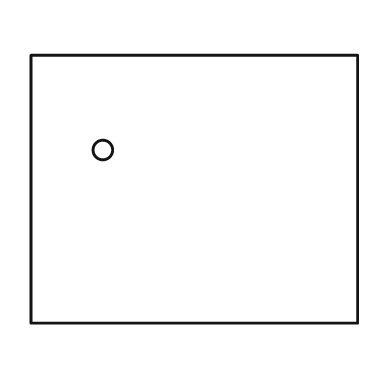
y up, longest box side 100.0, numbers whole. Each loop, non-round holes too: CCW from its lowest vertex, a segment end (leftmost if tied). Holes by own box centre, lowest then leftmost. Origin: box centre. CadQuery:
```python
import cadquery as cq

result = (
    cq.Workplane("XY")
    .moveTo(-50.0, -41.0)
    .lineTo(50.0, -41.0)
    .lineTo(50.0, 41.0)
    .lineTo(-50.0, 41.0)
    .close()
    .moveTo(-28.0, 12.0)
    .circle(3.0)
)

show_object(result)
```